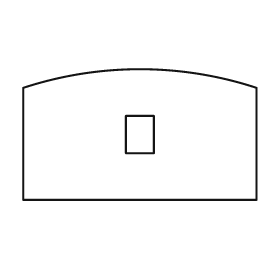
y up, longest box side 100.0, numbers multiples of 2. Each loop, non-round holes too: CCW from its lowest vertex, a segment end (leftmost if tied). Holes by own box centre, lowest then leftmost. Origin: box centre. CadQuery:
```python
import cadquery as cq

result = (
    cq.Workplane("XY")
    .moveTo(-50.0, -28.0)
    .lineTo(50.0, -28.0)
    .lineTo(50.0, 20.0)
    .threePointArc((0.0, 28.0), (-50.0, 20.0))
    .close()
    .moveTo(-6.0, -8.0)
    .lineTo(6.0, -8.0)
    .lineTo(6.0, 8.0)
    .lineTo(-6.0, 8.0)
    .close()
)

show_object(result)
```